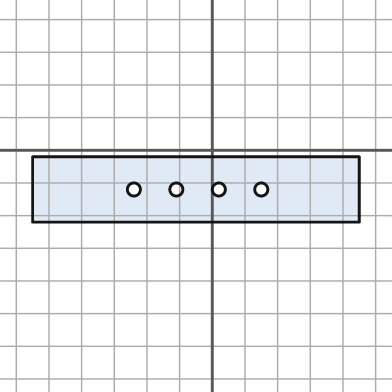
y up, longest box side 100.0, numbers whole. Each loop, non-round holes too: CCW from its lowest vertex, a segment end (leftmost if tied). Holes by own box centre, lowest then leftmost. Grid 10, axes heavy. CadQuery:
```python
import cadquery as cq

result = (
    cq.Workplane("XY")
    .moveTo(-55.0, -22.0)
    .lineTo(45.0, -22.0)
    .lineTo(45.0, -2.0)
    .lineTo(-55.0, -2.0)
    .close()
    .moveTo(-24.0, -12.0)
    .circle(2.0)
    .moveTo(-11.0, -12.0)
    .circle(2.0)
    .moveTo(2.0, -12.0)
    .circle(2.0)
    .moveTo(15.0, -12.0)
    .circle(2.0)
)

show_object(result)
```